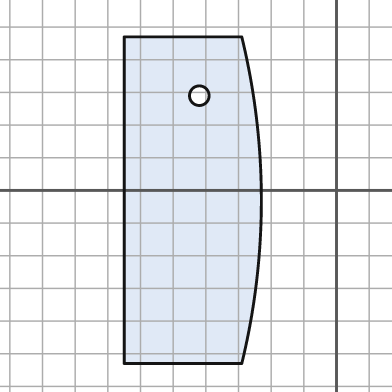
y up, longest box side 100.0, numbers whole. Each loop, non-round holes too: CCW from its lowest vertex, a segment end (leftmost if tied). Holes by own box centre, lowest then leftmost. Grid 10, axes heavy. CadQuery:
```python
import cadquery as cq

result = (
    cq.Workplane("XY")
    .moveTo(-65.0, -53.0)
    .lineTo(-29.0, -53.0)
    .threePointArc((-23.0, -3.0), (-29.0, 47.0))
    .lineTo(-65.0, 47.0)
    .close()
    .moveTo(-42.0, 29.0)
    .circle(3.0)
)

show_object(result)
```